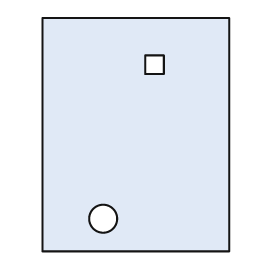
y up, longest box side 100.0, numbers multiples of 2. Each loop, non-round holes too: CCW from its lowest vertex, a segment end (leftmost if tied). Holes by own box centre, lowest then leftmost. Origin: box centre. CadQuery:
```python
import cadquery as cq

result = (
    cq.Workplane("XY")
    .moveTo(-40.0, -50.0)
    .lineTo(40.0, -50.0)
    .lineTo(40.0, 50.0)
    .lineTo(-40.0, 50.0)
    .close()
    .moveTo(-14.0, -36.0)
    .circle(6.0)
    .moveTo(4.0, 26.0)
    .lineTo(12.0, 26.0)
    .lineTo(12.0, 34.0)
    .lineTo(4.0, 34.0)
    .close()
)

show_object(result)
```